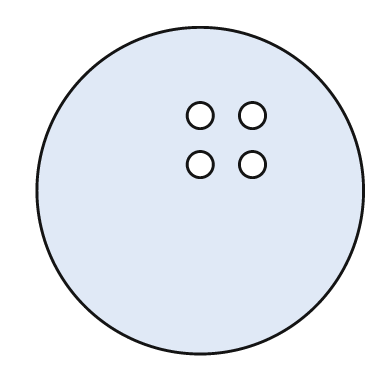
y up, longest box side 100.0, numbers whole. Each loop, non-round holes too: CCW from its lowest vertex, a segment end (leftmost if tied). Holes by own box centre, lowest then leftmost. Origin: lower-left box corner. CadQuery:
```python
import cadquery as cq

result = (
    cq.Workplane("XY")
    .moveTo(50.0, 50.0)
    .circle(50.0)
    .moveTo(50.0, 58.0)
    .circle(4.0)
    .moveTo(66.0, 58.0)
    .circle(4.0)
    .moveTo(50.0, 73.0)
    .circle(4.0)
    .moveTo(66.0, 73.0)
    .circle(4.0)
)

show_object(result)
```